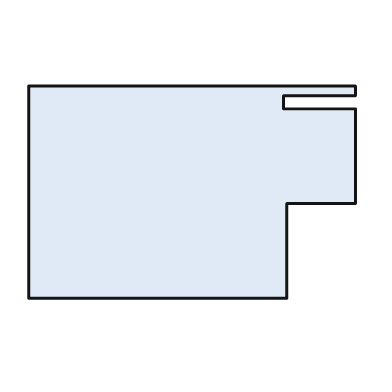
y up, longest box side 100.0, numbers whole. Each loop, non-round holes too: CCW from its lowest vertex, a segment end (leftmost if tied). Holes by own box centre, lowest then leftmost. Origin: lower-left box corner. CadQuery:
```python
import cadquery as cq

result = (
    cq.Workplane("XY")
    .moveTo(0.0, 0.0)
    .lineTo(79.0, 0.0)
    .lineTo(79.0, 29.0)
    .lineTo(100.0, 29.0)
    .lineTo(100.0, 58.0)
    .lineTo(78.0, 58.0)
    .lineTo(78.0, 62.0)
    .lineTo(100.0, 62.0)
    .lineTo(100.0, 65.0)
    .lineTo(0.0, 65.0)
    .close()
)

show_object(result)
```